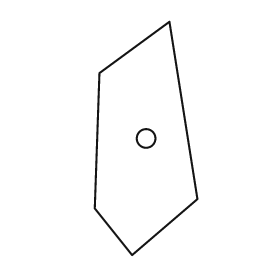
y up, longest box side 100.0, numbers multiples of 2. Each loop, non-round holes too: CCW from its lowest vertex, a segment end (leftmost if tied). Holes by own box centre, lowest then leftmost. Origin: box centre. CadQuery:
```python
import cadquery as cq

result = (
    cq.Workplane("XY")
    .moveTo(-6.0, -50.0)
    .lineTo(22.0, -26.0)
    .lineTo(10.0, 50.0)
    .lineTo(-20.0, 28.0)
    .lineTo(-22.0, -30.0)
    .close()
    .moveTo(0.0, 0.0)
    .circle(4.0)
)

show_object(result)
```